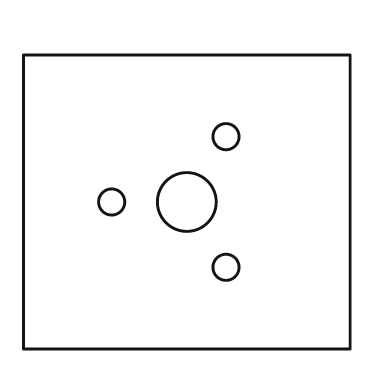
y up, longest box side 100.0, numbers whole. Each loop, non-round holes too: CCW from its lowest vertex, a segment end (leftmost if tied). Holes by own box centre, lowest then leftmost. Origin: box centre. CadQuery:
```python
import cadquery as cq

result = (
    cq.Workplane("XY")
    .moveTo(-50.0, -45.0)
    .lineTo(50.0, -45.0)
    .lineTo(50.0, 45.0)
    .lineTo(-50.0, 45.0)
    .close()
    .moveTo(12.0, -20.0)
    .circle(4.0)
    .moveTo(-23.0, 0.0)
    .circle(4.0)
    .moveTo(0.0, 0.0)
    .circle(9.0)
    .moveTo(12.0, 20.0)
    .circle(4.0)
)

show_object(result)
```